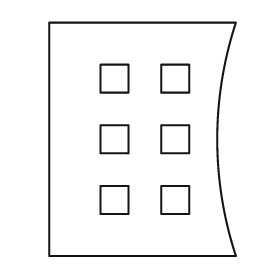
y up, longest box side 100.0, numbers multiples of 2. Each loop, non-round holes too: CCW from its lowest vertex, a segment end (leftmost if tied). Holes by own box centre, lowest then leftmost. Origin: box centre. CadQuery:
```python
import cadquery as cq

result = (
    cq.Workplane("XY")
    .moveTo(-40.0, -50.0)
    .lineTo(40.0, -50.0)
    .threePointArc((32.0, 0.0), (40.0, 50.0))
    .lineTo(-40.0, 50.0)
    .close()
    .moveTo(-18.0, -32.0)
    .lineTo(-6.0, -32.0)
    .lineTo(-6.0, -20.0)
    .lineTo(-18.0, -20.0)
    .close()
    .moveTo(8.0, -32.0)
    .lineTo(20.0, -32.0)
    .lineTo(20.0, -20.0)
    .lineTo(8.0, -20.0)
    .close()
    .moveTo(-18.0, -6.0)
    .lineTo(-6.0, -6.0)
    .lineTo(-6.0, 6.0)
    .lineTo(-18.0, 6.0)
    .close()
    .moveTo(8.0, -6.0)
    .lineTo(20.0, -6.0)
    .lineTo(20.0, 6.0)
    .lineTo(8.0, 6.0)
    .close()
    .moveTo(-18.0, 20.0)
    .lineTo(-6.0, 20.0)
    .lineTo(-6.0, 32.0)
    .lineTo(-18.0, 32.0)
    .close()
    .moveTo(8.0, 20.0)
    .lineTo(20.0, 20.0)
    .lineTo(20.0, 32.0)
    .lineTo(8.0, 32.0)
    .close()
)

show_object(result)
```